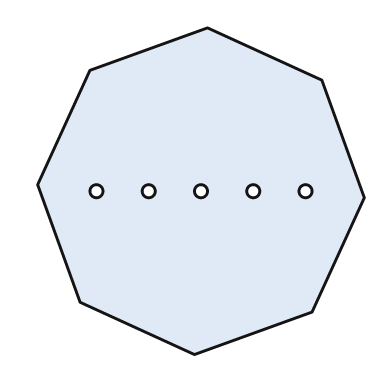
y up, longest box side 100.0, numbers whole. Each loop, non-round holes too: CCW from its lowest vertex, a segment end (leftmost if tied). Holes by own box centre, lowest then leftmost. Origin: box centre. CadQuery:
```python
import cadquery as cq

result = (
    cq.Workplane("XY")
    .moveTo(-2.0, -50.0)
    .lineTo(34.0, -37.0)
    .lineTo(50.0, -2.0)
    .lineTo(37.0, 34.0)
    .lineTo(2.0, 50.0)
    .lineTo(-34.0, 37.0)
    .lineTo(-50.0, 2.0)
    .lineTo(-37.0, -34.0)
    .close()
    .moveTo(-32.0, 0.0)
    .circle(2.0)
    .moveTo(-16.0, 0.0)
    .circle(2.0)
    .moveTo(0.0, 0.0)
    .circle(2.0)
    .moveTo(16.0, 0.0)
    .circle(2.0)
    .moveTo(32.0, 0.0)
    .circle(2.0)
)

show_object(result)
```